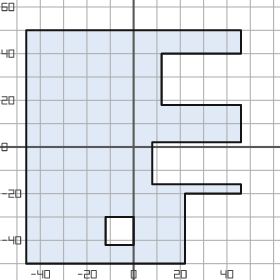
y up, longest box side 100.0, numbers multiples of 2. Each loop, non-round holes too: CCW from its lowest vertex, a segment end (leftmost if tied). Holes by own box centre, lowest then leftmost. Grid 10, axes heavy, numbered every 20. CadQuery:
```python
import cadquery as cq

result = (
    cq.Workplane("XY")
    .moveTo(-46.0, -50.0)
    .lineTo(22.0, -50.0)
    .lineTo(22.0, -20.0)
    .lineTo(46.0, -20.0)
    .lineTo(46.0, -16.0)
    .lineTo(8.0, -16.0)
    .lineTo(8.0, 2.0)
    .lineTo(46.0, 2.0)
    .lineTo(46.0, 18.0)
    .lineTo(12.0, 18.0)
    .lineTo(12.0, 40.0)
    .lineTo(46.0, 40.0)
    .lineTo(46.0, 50.0)
    .lineTo(-46.0, 50.0)
    .close()
    .moveTo(-12.0, -42.0)
    .lineTo(0.0, -42.0)
    .lineTo(0.0, -30.0)
    .lineTo(-12.0, -30.0)
    .close()
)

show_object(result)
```